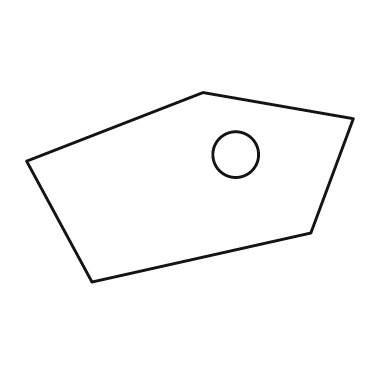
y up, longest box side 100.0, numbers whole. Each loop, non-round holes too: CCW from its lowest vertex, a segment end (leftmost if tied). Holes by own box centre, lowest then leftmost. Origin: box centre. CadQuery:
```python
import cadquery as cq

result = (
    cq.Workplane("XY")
    .moveTo(-30.0, -29.0)
    .lineTo(37.0, -14.0)
    .lineTo(50.0, 21.0)
    .lineTo(4.0, 29.0)
    .lineTo(-50.0, 8.0)
    .close()
    .moveTo(14.0, 10.0)
    .circle(7.0)
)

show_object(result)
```